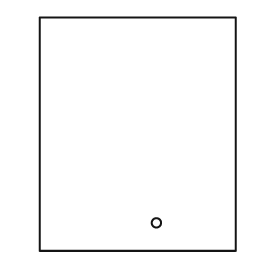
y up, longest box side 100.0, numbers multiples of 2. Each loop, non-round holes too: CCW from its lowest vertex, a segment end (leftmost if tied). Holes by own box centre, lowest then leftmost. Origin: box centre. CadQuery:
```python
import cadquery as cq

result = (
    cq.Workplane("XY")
    .moveTo(-42.0, -50.0)
    .lineTo(42.0, -50.0)
    .lineTo(42.0, 50.0)
    .lineTo(-42.0, 50.0)
    .close()
    .moveTo(8.0, -38.0)
    .circle(2.0)
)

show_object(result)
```